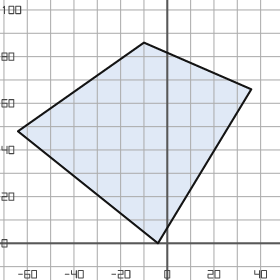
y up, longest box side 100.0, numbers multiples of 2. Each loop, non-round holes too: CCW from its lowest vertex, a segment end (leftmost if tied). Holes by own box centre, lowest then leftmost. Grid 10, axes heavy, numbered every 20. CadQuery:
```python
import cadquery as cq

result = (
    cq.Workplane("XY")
    .moveTo(-4.0, 0.0)
    .lineTo(36.0, 66.0)
    .lineTo(-10.0, 86.0)
    .lineTo(-64.0, 48.0)
    .close()
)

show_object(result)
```